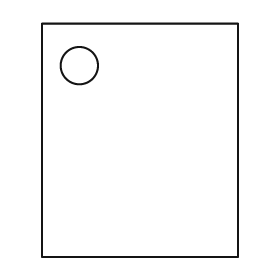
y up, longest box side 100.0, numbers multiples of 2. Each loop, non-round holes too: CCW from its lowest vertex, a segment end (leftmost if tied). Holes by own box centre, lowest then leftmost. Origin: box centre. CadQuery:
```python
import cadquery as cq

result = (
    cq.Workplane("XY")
    .moveTo(-42.0, -50.0)
    .lineTo(42.0, -50.0)
    .lineTo(42.0, 50.0)
    .lineTo(-42.0, 50.0)
    .close()
    .moveTo(-26.0, 32.0)
    .circle(8.0)
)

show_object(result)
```